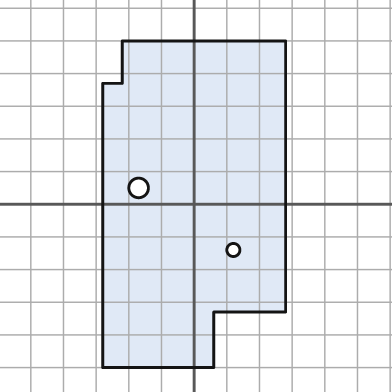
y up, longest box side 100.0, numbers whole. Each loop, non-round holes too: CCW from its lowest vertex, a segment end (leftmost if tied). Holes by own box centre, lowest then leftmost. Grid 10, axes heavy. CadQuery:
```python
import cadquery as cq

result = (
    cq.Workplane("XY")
    .moveTo(-28.0, -50.0)
    .lineTo(6.0, -50.0)
    .lineTo(6.0, -33.0)
    .lineTo(28.0, -33.0)
    .lineTo(28.0, 50.0)
    .lineTo(-22.0, 50.0)
    .lineTo(-22.0, 37.0)
    .lineTo(-28.0, 37.0)
    .close()
    .moveTo(12.0, -14.0)
    .circle(2.0)
    .moveTo(-17.0, 5.0)
    .circle(3.0)
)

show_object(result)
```